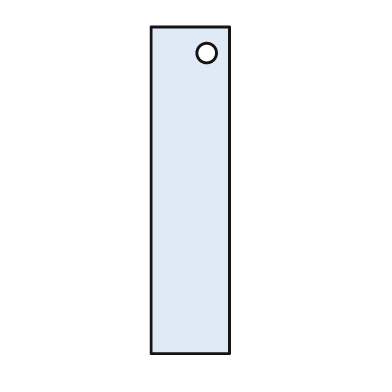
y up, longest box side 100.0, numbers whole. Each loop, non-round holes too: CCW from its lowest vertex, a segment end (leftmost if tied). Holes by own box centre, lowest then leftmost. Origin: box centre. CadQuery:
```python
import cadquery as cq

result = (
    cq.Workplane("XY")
    .moveTo(-12.0, -50.0)
    .lineTo(12.0, -50.0)
    .lineTo(12.0, 50.0)
    .lineTo(-12.0, 50.0)
    .close()
    .moveTo(5.0, 42.0)
    .circle(3.0)
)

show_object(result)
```